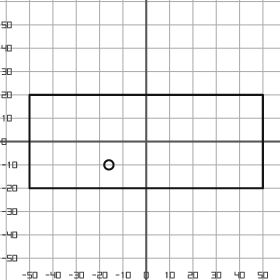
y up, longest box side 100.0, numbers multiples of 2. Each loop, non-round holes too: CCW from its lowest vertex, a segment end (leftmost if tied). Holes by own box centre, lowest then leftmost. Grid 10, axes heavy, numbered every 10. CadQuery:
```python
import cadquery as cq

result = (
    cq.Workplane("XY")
    .moveTo(-50.0, -20.0)
    .lineTo(50.0, -20.0)
    .lineTo(50.0, 20.0)
    .lineTo(-50.0, 20.0)
    .close()
    .moveTo(-16.0, -10.0)
    .circle(2.0)
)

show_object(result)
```